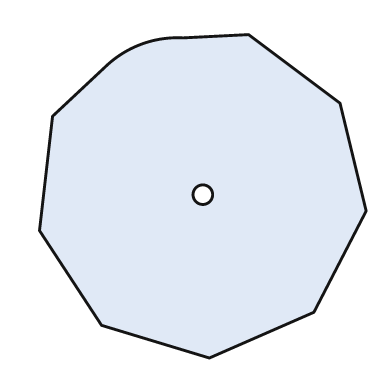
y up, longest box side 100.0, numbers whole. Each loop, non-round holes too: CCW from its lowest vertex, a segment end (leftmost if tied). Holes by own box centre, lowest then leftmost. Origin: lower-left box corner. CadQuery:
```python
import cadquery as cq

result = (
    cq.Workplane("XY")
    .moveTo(52.0, 0.0)
    .lineTo(84.0, 14.0)
    .lineTo(100.0, 45.0)
    .lineTo(92.0, 78.0)
    .lineTo(64.0, 99.0)
    .lineTo(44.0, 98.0)
    .threePointArc((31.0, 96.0), (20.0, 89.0))
    .lineTo(4.0, 74.0)
    .lineTo(0.0, 39.0)
    .lineTo(19.0, 10.0)
    .close()
    .moveTo(50.0, 50.0)
    .circle(3.0)
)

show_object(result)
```